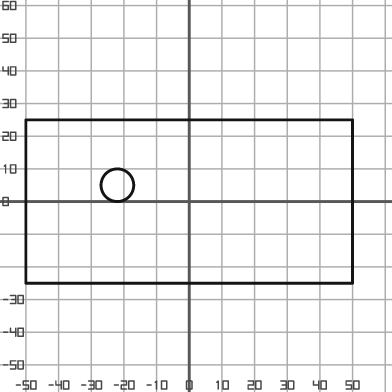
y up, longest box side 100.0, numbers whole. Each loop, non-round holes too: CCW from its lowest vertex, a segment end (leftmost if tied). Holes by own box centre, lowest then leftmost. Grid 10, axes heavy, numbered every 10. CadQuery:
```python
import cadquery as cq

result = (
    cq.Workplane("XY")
    .moveTo(-50.0, -25.0)
    .lineTo(50.0, -25.0)
    .lineTo(50.0, 25.0)
    .lineTo(-50.0, 25.0)
    .close()
    .moveTo(-22.0, 5.0)
    .circle(5.0)
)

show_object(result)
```